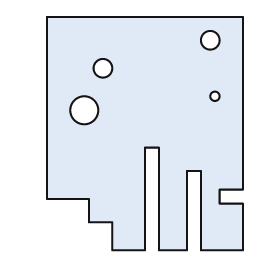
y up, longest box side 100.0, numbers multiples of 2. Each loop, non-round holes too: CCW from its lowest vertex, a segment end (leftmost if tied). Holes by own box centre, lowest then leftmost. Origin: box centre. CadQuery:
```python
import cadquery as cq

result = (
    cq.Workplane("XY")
    .moveTo(-14.0, -50.0)
    .lineTo(0.0, -50.0)
    .lineTo(0.0, -6.0)
    .lineTo(6.0, -6.0)
    .lineTo(6.0, -50.0)
    .lineTo(18.0, -50.0)
    .lineTo(18.0, -16.0)
    .lineTo(24.0, -16.0)
    .lineTo(24.0, -50.0)
    .lineTo(42.0, -50.0)
    .lineTo(42.0, -30.0)
    .lineTo(32.0, -30.0)
    .lineTo(32.0, -24.0)
    .lineTo(42.0, -24.0)
    .lineTo(42.0, 50.0)
    .lineTo(-42.0, 50.0)
    .lineTo(-42.0, -28.0)
    .lineTo(-24.0, -28.0)
    .lineTo(-24.0, -38.0)
    .lineTo(-14.0, -38.0)
    .close()
    .moveTo(-26.0, 10.0)
    .circle(6.0)
    .moveTo(30.0, 16.0)
    .circle(2.0)
    .moveTo(-18.0, 28.0)
    .circle(4.0)
    .moveTo(28.0, 40.0)
    .circle(4.0)
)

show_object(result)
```